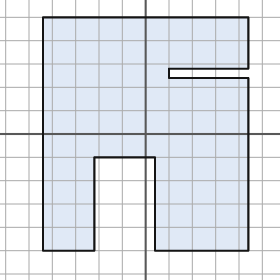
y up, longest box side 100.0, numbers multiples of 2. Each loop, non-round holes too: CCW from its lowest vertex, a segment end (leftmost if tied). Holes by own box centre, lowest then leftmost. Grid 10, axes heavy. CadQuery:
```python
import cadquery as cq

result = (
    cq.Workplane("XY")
    .moveTo(-44.0, -50.0)
    .lineTo(-22.0, -50.0)
    .lineTo(-22.0, -10.0)
    .lineTo(4.0, -10.0)
    .lineTo(4.0, -50.0)
    .lineTo(44.0, -50.0)
    .lineTo(44.0, 24.0)
    .lineTo(10.0, 24.0)
    .lineTo(10.0, 28.0)
    .lineTo(44.0, 28.0)
    .lineTo(44.0, 50.0)
    .lineTo(-44.0, 50.0)
    .close()
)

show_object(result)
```